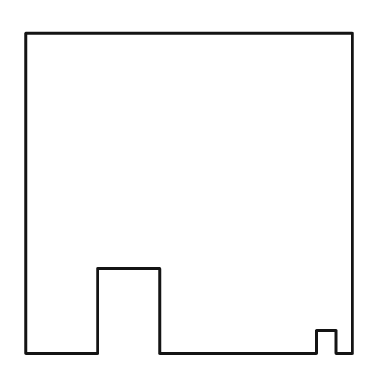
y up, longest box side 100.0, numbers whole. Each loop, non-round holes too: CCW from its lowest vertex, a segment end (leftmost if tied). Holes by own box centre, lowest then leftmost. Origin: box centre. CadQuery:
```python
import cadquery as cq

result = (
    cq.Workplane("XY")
    .moveTo(-50.0, -49.0)
    .lineTo(-28.0, -49.0)
    .lineTo(-28.0, -23.0)
    .lineTo(-9.0, -23.0)
    .lineTo(-9.0, -49.0)
    .lineTo(39.0, -49.0)
    .lineTo(39.0, -42.0)
    .lineTo(45.0, -42.0)
    .lineTo(45.0, -49.0)
    .lineTo(50.0, -49.0)
    .lineTo(50.0, 49.0)
    .lineTo(-50.0, 49.0)
    .close()
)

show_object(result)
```